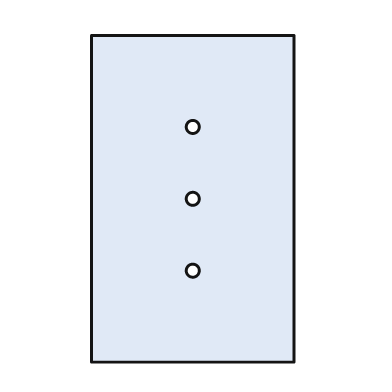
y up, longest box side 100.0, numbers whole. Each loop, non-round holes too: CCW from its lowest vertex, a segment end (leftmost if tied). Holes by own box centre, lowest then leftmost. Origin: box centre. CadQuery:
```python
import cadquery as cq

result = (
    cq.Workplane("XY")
    .moveTo(-31.0, -50.0)
    .lineTo(31.0, -50.0)
    .lineTo(31.0, 50.0)
    .lineTo(-31.0, 50.0)
    .close()
    .moveTo(0.0, -22.0)
    .circle(2.0)
    .moveTo(0.0, 0.0)
    .circle(2.0)
    .moveTo(0.0, 22.0)
    .circle(2.0)
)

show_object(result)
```